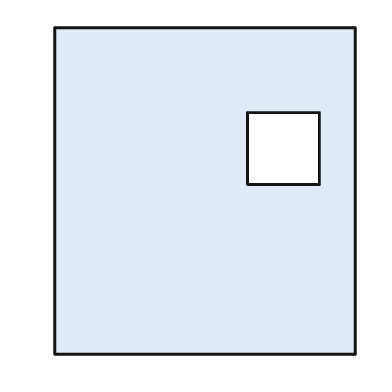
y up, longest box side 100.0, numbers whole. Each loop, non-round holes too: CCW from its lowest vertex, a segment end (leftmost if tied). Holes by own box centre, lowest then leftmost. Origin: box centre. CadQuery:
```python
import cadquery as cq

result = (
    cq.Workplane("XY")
    .moveTo(-46.0, -50.0)
    .lineTo(46.0, -50.0)
    .lineTo(46.0, 50.0)
    .lineTo(-46.0, 50.0)
    .close()
    .moveTo(13.0, 2.0)
    .lineTo(35.0, 2.0)
    .lineTo(35.0, 24.0)
    .lineTo(13.0, 24.0)
    .close()
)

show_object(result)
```